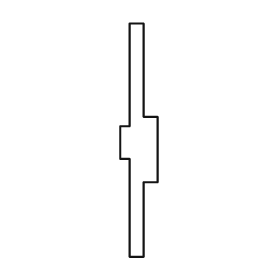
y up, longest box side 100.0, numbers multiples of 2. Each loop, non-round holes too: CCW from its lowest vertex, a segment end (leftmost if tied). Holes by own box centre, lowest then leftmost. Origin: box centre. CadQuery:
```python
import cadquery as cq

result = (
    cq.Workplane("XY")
    .moveTo(-4.0, -50.0)
    .lineTo(2.0, -50.0)
    .lineTo(2.0, -18.0)
    .lineTo(8.0, -18.0)
    .lineTo(8.0, 10.0)
    .lineTo(2.0, 10.0)
    .lineTo(2.0, 50.0)
    .lineTo(-4.0, 50.0)
    .lineTo(-4.0, 6.0)
    .lineTo(-8.0, 6.0)
    .lineTo(-8.0, -8.0)
    .lineTo(-4.0, -8.0)
    .close()
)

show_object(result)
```